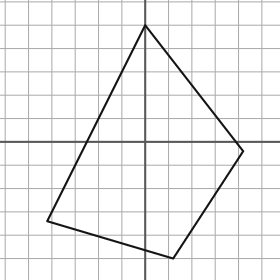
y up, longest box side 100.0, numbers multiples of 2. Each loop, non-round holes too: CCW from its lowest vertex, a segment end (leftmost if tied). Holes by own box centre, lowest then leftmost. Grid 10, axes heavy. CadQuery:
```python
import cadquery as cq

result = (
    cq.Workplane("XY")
    .moveTo(12.0, -50.0)
    .lineTo(42.0, -4.0)
    .lineTo(0.0, 50.0)
    .lineTo(-42.0, -34.0)
    .close()
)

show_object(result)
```